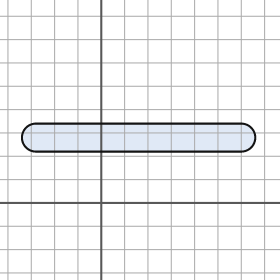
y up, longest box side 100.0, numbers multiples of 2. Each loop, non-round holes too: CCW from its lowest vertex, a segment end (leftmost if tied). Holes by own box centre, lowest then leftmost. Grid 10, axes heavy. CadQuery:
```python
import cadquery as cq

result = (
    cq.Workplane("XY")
    .moveTo(-28.0, 22.0)
    .lineTo(60.0, 22.0)
    .threePointArc((66.0, 28.0), (60.0, 34.0))
    .lineTo(-28.0, 34.0)
    .threePointArc((-34.0, 28.0), (-28.0, 22.0))
    .close()
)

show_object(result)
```